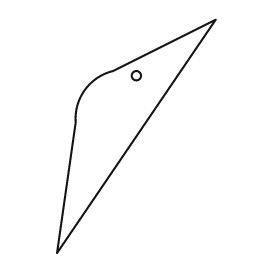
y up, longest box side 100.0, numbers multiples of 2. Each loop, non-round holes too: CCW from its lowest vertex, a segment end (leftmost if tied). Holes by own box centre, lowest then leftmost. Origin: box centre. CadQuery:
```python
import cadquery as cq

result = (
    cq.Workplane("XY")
    .moveTo(-34.0, -50.0)
    .lineTo(34.0, 50.0)
    .lineTo(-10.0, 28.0)
    .threePointArc((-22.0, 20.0), (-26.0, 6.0))
    .close()
    .moveTo(0.0, 26.0)
    .circle(2.0)
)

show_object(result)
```